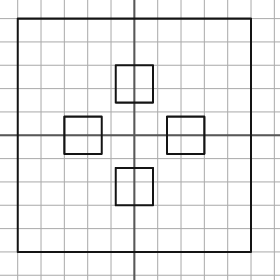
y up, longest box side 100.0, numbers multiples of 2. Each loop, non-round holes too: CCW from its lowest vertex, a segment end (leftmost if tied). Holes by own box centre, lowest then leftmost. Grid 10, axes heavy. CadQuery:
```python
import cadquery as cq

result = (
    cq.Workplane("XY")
    .moveTo(-50.0, -50.0)
    .lineTo(50.0, -50.0)
    .lineTo(50.0, 50.0)
    .lineTo(-50.0, 50.0)
    .close()
    .moveTo(-8.0, -30.0)
    .lineTo(8.0, -30.0)
    .lineTo(8.0, -14.0)
    .lineTo(-8.0, -14.0)
    .close()
    .moveTo(-30.0, -8.0)
    .lineTo(-14.0, -8.0)
    .lineTo(-14.0, 8.0)
    .lineTo(-30.0, 8.0)
    .close()
    .moveTo(14.0, -8.0)
    .lineTo(30.0, -8.0)
    .lineTo(30.0, 8.0)
    .lineTo(14.0, 8.0)
    .close()
    .moveTo(-8.0, 14.0)
    .lineTo(8.0, 14.0)
    .lineTo(8.0, 30.0)
    .lineTo(-8.0, 30.0)
    .close()
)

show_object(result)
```